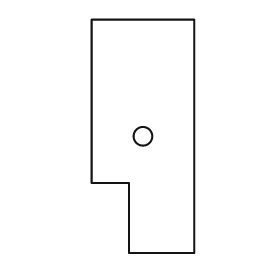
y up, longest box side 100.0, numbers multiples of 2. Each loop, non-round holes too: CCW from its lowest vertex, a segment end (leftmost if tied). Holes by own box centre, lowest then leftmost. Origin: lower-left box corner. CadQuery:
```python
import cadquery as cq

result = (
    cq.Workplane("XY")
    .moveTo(16.0, 0.0)
    .lineTo(44.0, 0.0)
    .lineTo(44.0, 100.0)
    .lineTo(0.0, 100.0)
    .lineTo(0.0, 30.0)
    .lineTo(16.0, 30.0)
    .close()
    .moveTo(22.0, 50.0)
    .circle(4.0)
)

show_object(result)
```